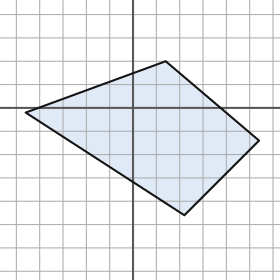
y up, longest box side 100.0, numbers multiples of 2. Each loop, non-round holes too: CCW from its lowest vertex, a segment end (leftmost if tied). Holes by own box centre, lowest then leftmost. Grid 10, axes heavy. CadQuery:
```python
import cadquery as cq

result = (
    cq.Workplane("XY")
    .moveTo(22.0, -46.0)
    .lineTo(54.0, -14.0)
    .lineTo(14.0, 20.0)
    .lineTo(-46.0, -2.0)
    .close()
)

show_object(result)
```